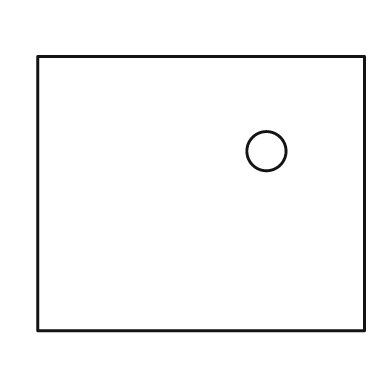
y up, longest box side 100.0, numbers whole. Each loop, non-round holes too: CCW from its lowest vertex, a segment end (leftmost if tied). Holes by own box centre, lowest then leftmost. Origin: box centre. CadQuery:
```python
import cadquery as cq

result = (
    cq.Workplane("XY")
    .moveTo(-50.0, -42.0)
    .lineTo(50.0, -42.0)
    .lineTo(50.0, 42.0)
    .lineTo(-50.0, 42.0)
    .close()
    .moveTo(20.0, 13.0)
    .circle(6.0)
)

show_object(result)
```